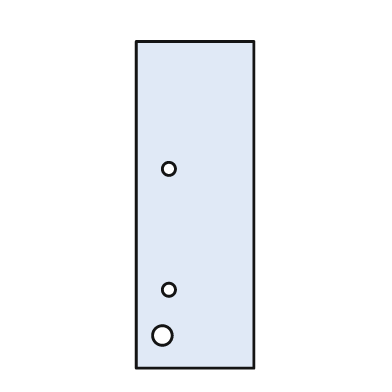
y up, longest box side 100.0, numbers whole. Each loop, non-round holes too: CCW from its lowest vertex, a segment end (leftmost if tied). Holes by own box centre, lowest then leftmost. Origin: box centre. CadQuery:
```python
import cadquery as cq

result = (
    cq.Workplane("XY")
    .moveTo(-18.0, -50.0)
    .lineTo(18.0, -50.0)
    .lineTo(18.0, 50.0)
    .lineTo(-18.0, 50.0)
    .close()
    .moveTo(-10.0, -40.0)
    .circle(3.0)
    .moveTo(-8.0, -26.0)
    .circle(2.0)
    .moveTo(-8.0, 11.0)
    .circle(2.0)
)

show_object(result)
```